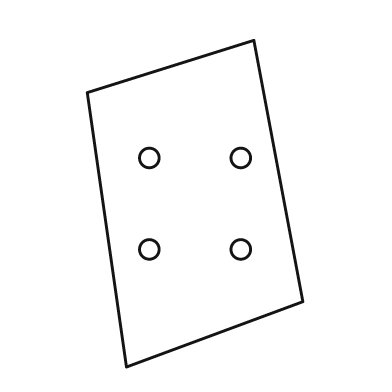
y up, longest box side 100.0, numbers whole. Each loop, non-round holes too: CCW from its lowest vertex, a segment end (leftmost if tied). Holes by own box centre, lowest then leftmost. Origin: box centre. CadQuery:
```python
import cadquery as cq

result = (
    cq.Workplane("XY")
    .moveTo(-21.0, -50.0)
    .lineTo(33.0, -30.0)
    .lineTo(18.0, 50.0)
    .lineTo(-33.0, 34.0)
    .close()
    .moveTo(-14.0, -14.0)
    .circle(3.0)
    .moveTo(14.0, -14.0)
    .circle(3.0)
    .moveTo(-14.0, 14.0)
    .circle(3.0)
    .moveTo(14.0, 14.0)
    .circle(3.0)
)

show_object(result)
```